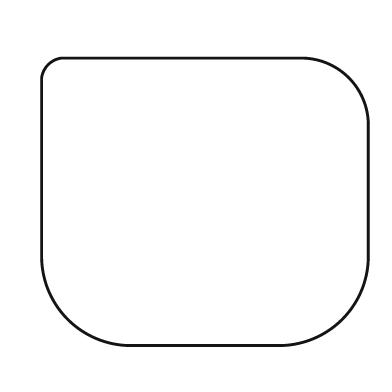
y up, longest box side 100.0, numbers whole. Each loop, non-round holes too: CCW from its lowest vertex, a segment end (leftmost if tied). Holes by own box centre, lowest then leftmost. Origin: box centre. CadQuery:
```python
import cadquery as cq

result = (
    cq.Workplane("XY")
    .moveTo(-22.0, -44.0)
    .lineTo(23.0, -44.0)
    .threePointArc((42.0, -36.0), (50.0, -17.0))
    .lineTo(50.0, 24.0)
    .threePointArc((44.0, 38.0), (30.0, 44.0))
    .lineTo(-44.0, 44.0)
    .threePointArc((-48.0, 42.0), (-50.0, 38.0))
    .lineTo(-50.0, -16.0)
    .threePointArc((-42.0, -36.0), (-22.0, -44.0))
    .close()
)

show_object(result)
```